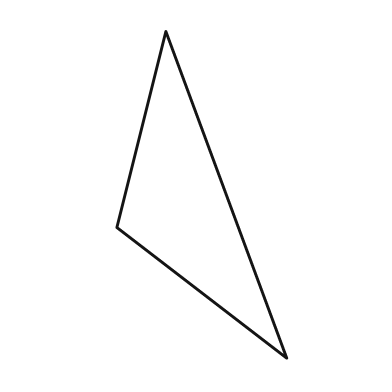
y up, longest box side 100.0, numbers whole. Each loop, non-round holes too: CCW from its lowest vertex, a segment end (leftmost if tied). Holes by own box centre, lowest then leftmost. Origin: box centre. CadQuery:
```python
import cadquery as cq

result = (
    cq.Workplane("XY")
    .moveTo(26.0, -50.0)
    .lineTo(-11.0, 50.0)
    .lineTo(-26.0, -10.0)
    .close()
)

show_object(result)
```